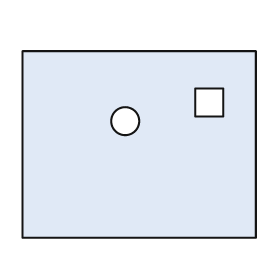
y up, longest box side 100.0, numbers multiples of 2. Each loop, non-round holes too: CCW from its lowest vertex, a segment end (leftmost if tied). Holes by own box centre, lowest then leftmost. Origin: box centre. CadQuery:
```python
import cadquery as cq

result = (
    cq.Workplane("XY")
    .moveTo(-50.0, -40.0)
    .lineTo(50.0, -40.0)
    .lineTo(50.0, 40.0)
    .lineTo(-50.0, 40.0)
    .close()
    .moveTo(-6.0, 10.0)
    .circle(6.0)
    .moveTo(24.0, 12.0)
    .lineTo(36.0, 12.0)
    .lineTo(36.0, 24.0)
    .lineTo(24.0, 24.0)
    .close()
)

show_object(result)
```